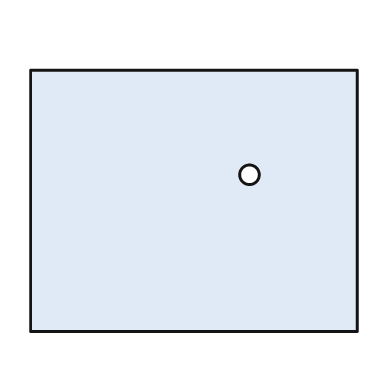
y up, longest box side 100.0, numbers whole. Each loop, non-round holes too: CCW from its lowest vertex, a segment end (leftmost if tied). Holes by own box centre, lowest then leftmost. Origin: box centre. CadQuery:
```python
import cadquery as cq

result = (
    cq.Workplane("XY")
    .moveTo(-50.0, -40.0)
    .lineTo(50.0, -40.0)
    .lineTo(50.0, 40.0)
    .lineTo(-50.0, 40.0)
    .close()
    .moveTo(17.0, 8.0)
    .circle(3.0)
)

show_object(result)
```